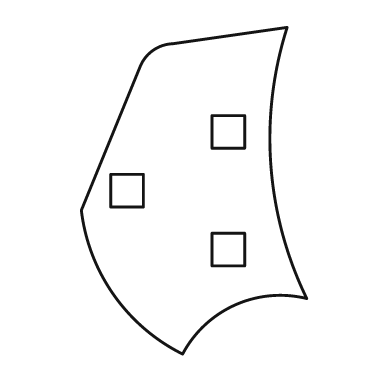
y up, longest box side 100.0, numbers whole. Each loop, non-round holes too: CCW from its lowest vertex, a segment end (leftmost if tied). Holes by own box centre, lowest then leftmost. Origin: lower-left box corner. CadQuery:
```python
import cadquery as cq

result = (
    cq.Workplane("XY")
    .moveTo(31.0, 0.0)
    .threePointArc((47.0, 15.0), (69.0, 17.0))
    .threePointArc((58.0, 58.0), (63.0, 100.0))
    .lineTo(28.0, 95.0)
    .threePointArc((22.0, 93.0), (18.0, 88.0))
    .lineTo(0.0, 44.0)
    .threePointArc((10.0, 18.0), (31.0, 0.0))
    .close()
    .moveTo(40.0, 27.0)
    .lineTo(50.0, 27.0)
    .lineTo(50.0, 37.0)
    .lineTo(40.0, 37.0)
    .close()
    .moveTo(9.0, 45.0)
    .lineTo(19.0, 45.0)
    .lineTo(19.0, 55.0)
    .lineTo(9.0, 55.0)
    .close()
    .moveTo(40.0, 63.0)
    .lineTo(50.0, 63.0)
    .lineTo(50.0, 73.0)
    .lineTo(40.0, 73.0)
    .close()
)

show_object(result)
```